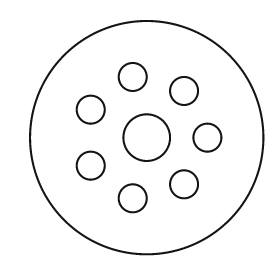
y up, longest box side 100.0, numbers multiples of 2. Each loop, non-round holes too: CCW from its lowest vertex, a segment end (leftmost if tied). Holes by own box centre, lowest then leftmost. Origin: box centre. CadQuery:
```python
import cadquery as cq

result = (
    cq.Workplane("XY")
    .moveTo(0.0, 0.0)
    .circle(50.0)
    .moveTo(-6.0, -26.0)
    .circle(6.0)
    .moveTo(16.0, -20.0)
    .circle(6.0)
    .moveTo(-24.0, -12.0)
    .circle(6.0)
    .moveTo(0.0, 0.0)
    .circle(10.0)
    .moveTo(26.0, 0.0)
    .circle(6.0)
    .moveTo(-24.0, 12.0)
    .circle(6.0)
    .moveTo(16.0, 20.0)
    .circle(6.0)
    .moveTo(-6.0, 26.0)
    .circle(6.0)
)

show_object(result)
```